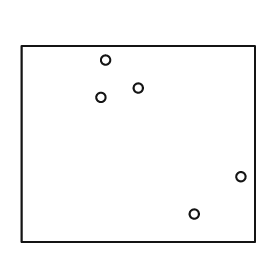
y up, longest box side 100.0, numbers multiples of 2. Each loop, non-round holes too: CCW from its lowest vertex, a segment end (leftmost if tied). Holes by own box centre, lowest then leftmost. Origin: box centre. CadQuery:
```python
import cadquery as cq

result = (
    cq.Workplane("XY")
    .moveTo(-50.0, -42.0)
    .lineTo(50.0, -42.0)
    .lineTo(50.0, 42.0)
    .lineTo(-50.0, 42.0)
    .close()
    .moveTo(24.0, -30.0)
    .circle(2.0)
    .moveTo(44.0, -14.0)
    .circle(2.0)
    .moveTo(-16.0, 20.0)
    .circle(2.0)
    .moveTo(0.0, 24.0)
    .circle(2.0)
    .moveTo(-14.0, 36.0)
    .circle(2.0)
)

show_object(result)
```